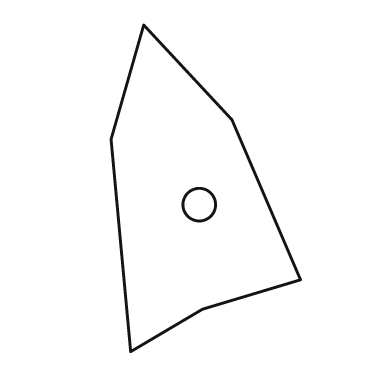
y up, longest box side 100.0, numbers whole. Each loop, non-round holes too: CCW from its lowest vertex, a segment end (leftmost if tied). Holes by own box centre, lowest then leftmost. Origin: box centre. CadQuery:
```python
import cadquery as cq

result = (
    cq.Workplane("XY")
    .moveTo(-23.0, -50.0)
    .lineTo(-1.0, -37.0)
    .lineTo(29.0, -28.0)
    .lineTo(8.0, 21.0)
    .lineTo(-19.0, 50.0)
    .lineTo(-29.0, 15.0)
    .close()
    .moveTo(-2.0, -5.0)
    .circle(5.0)
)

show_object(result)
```